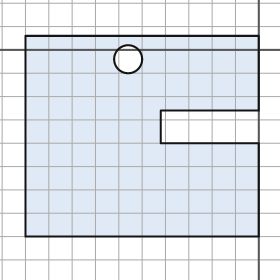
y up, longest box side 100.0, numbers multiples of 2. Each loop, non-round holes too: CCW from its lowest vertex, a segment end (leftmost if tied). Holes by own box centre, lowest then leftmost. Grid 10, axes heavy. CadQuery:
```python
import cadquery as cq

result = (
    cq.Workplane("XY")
    .moveTo(-100.0, -80.0)
    .lineTo(0.0, -80.0)
    .lineTo(0.0, -40.0)
    .lineTo(-42.0, -40.0)
    .lineTo(-42.0, -26.0)
    .lineTo(0.0, -26.0)
    .lineTo(0.0, 6.0)
    .lineTo(-100.0, 6.0)
    .close()
    .moveTo(-56.0, -4.0)
    .circle(6.0)
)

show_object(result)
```